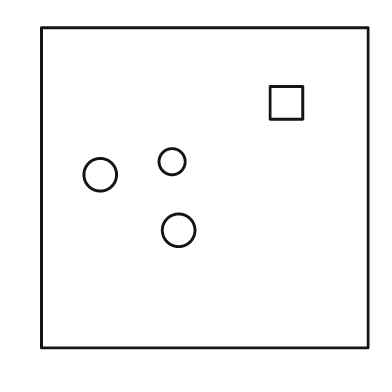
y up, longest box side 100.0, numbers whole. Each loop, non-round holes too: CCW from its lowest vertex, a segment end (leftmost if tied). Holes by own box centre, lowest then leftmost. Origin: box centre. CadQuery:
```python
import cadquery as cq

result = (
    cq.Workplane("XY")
    .moveTo(-50.0, -49.0)
    .lineTo(50.0, -49.0)
    .lineTo(50.0, 49.0)
    .lineTo(-50.0, 49.0)
    .close()
    .moveTo(-8.0, -13.0)
    .circle(5.0)
    .moveTo(-32.0, 4.0)
    .circle(5.0)
    .moveTo(-10.0, 8.0)
    .circle(4.0)
    .moveTo(20.0, 21.0)
    .lineTo(30.0, 21.0)
    .lineTo(30.0, 31.0)
    .lineTo(20.0, 31.0)
    .close()
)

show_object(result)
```